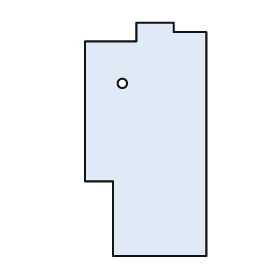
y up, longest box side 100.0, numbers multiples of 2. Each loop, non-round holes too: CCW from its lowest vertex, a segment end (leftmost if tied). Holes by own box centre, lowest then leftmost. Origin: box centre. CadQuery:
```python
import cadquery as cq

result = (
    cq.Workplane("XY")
    .moveTo(-14.0, -50.0)
    .lineTo(26.0, -50.0)
    .lineTo(26.0, 46.0)
    .lineTo(12.0, 46.0)
    .lineTo(12.0, 50.0)
    .lineTo(-4.0, 50.0)
    .lineTo(-4.0, 42.0)
    .lineTo(-26.0, 42.0)
    .lineTo(-26.0, -18.0)
    .lineTo(-14.0, -18.0)
    .close()
    .moveTo(-10.0, 24.0)
    .circle(2.0)
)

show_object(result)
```